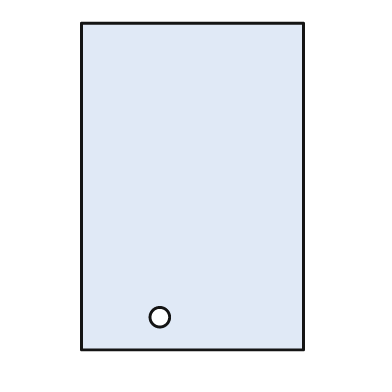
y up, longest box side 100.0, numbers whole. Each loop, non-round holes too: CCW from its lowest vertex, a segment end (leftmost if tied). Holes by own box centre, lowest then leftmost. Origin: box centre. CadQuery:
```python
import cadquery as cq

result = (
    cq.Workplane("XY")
    .moveTo(-34.0, -50.0)
    .lineTo(34.0, -50.0)
    .lineTo(34.0, 50.0)
    .lineTo(-34.0, 50.0)
    .close()
    .moveTo(-10.0, -40.0)
    .circle(3.0)
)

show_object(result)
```